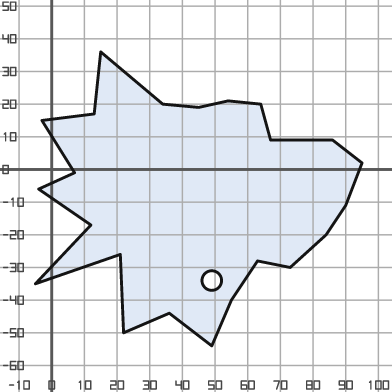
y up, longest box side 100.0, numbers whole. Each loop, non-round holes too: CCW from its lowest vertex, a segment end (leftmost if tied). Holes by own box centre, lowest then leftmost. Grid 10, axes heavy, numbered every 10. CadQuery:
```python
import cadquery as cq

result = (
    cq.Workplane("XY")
    .moveTo(49.0, -54.0)
    .lineTo(55.0, -40.0)
    .lineTo(63.0, -28.0)
    .lineTo(73.0, -30.0)
    .lineTo(84.0, -20.0)
    .lineTo(90.0, -11.0)
    .lineTo(95.0, 2.0)
    .lineTo(86.0, 9.0)
    .lineTo(67.0, 9.0)
    .lineTo(64.0, 20.0)
    .lineTo(54.0, 21.0)
    .lineTo(45.0, 19.0)
    .lineTo(34.0, 20.0)
    .lineTo(15.0, 36.0)
    .lineTo(13.0, 17.0)
    .lineTo(-3.0, 15.0)
    .lineTo(7.0, -1.0)
    .lineTo(-4.0, -6.0)
    .lineTo(12.0, -17.0)
    .lineTo(-5.0, -35.0)
    .lineTo(21.0, -26.0)
    .lineTo(22.0, -50.0)
    .lineTo(36.0, -44.0)
    .close()
    .moveTo(49.0, -34.0)
    .circle(3.0)
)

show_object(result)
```